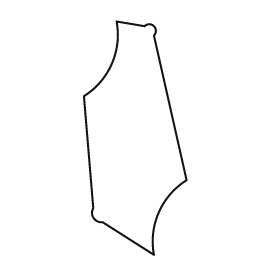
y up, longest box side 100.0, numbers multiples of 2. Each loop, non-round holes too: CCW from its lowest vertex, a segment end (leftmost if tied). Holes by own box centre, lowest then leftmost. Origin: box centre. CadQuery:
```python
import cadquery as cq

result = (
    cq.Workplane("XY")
    .moveTo(8.0, -50.0)
    .threePointArc((10.0, -32.0), (22.0, -18.0))
    .lineTo(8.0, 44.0)
    .threePointArc((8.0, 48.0), (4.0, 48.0))
    .lineTo(-8.0, 50.0)
    .threePointArc((-10.0, 32.0), (-22.0, 18.0))
    .lineTo(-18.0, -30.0)
    .threePointArc((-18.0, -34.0), (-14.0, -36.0))
    .close()
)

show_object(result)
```